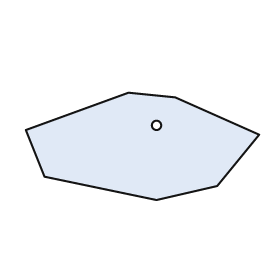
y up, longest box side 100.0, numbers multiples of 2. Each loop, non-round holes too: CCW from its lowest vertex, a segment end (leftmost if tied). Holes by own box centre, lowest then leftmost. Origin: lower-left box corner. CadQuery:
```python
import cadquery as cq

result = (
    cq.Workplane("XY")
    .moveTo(56.0, 0.0)
    .lineTo(82.0, 6.0)
    .lineTo(100.0, 28.0)
    .lineTo(64.0, 44.0)
    .lineTo(44.0, 46.0)
    .lineTo(0.0, 30.0)
    .lineTo(8.0, 10.0)
    .close()
    .moveTo(56.0, 32.0)
    .circle(2.0)
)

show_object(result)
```